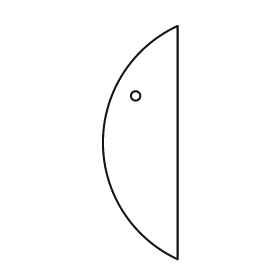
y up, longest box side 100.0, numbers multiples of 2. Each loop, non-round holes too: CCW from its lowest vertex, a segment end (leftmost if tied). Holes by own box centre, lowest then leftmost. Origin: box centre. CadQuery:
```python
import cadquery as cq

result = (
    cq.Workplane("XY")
    .moveTo(16.0, -50.0)
    .lineTo(16.0, 50.0)
    .threePointArc((-16.0, 0.0), (16.0, -50.0))
    .close()
    .moveTo(-2.0, 20.0)
    .circle(2.0)
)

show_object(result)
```